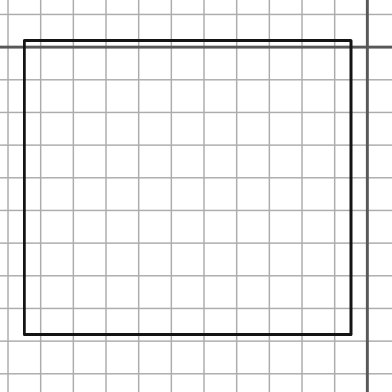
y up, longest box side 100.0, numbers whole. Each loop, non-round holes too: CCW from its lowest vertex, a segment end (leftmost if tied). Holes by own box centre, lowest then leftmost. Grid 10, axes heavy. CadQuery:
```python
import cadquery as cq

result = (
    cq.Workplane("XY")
    .moveTo(-105.0, -88.0)
    .lineTo(-5.0, -88.0)
    .lineTo(-5.0, 2.0)
    .lineTo(-105.0, 2.0)
    .close()
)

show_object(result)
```